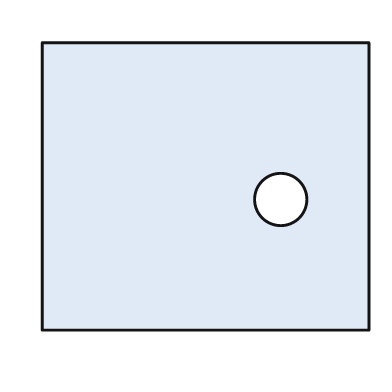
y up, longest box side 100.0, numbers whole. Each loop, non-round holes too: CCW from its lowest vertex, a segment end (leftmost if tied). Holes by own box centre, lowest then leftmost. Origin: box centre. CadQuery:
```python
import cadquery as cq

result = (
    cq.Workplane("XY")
    .moveTo(-50.0, -44.0)
    .lineTo(50.0, -44.0)
    .lineTo(50.0, 44.0)
    .lineTo(-50.0, 44.0)
    .close()
    .moveTo(23.0, -4.0)
    .circle(8.0)
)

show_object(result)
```